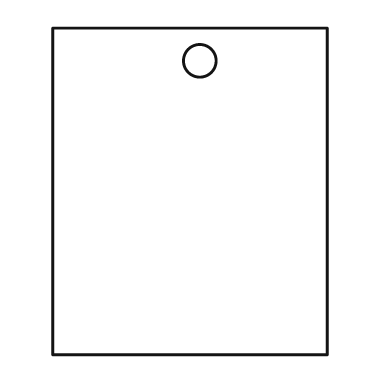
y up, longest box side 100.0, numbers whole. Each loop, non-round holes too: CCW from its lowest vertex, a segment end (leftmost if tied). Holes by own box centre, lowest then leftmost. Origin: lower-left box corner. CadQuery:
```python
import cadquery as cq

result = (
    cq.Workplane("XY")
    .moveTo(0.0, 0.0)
    .lineTo(84.0, 0.0)
    .lineTo(84.0, 100.0)
    .lineTo(0.0, 100.0)
    .close()
    .moveTo(45.0, 90.0)
    .circle(5.0)
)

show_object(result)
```